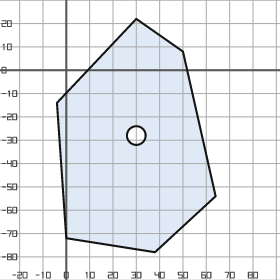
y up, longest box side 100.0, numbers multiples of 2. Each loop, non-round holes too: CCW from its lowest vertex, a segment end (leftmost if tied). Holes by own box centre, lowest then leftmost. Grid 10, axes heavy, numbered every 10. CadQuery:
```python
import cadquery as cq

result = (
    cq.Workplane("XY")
    .moveTo(38.0, -78.0)
    .lineTo(64.0, -54.0)
    .lineTo(50.0, 8.0)
    .lineTo(30.0, 22.0)
    .lineTo(-4.0, -14.0)
    .lineTo(0.0, -72.0)
    .close()
    .moveTo(30.0, -28.0)
    .circle(4.0)
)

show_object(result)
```